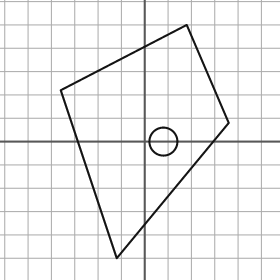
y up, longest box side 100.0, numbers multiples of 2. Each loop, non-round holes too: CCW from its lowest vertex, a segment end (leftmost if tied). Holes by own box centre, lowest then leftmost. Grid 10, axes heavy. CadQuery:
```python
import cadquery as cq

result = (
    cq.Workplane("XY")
    .moveTo(-12.0, -50.0)
    .lineTo(36.0, 8.0)
    .lineTo(18.0, 50.0)
    .lineTo(-36.0, 22.0)
    .close()
    .moveTo(8.0, 0.0)
    .circle(6.0)
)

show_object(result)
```